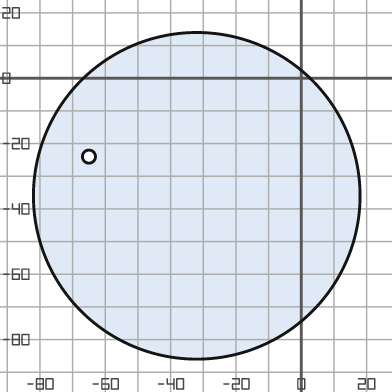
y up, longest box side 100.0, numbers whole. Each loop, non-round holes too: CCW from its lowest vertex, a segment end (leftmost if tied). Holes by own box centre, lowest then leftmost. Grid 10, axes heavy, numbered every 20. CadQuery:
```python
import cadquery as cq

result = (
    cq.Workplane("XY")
    .moveTo(-32.0, -36.0)
    .circle(50.0)
    .moveTo(-65.0, -24.0)
    .circle(2.0)
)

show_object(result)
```